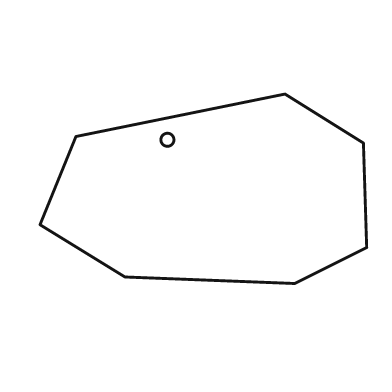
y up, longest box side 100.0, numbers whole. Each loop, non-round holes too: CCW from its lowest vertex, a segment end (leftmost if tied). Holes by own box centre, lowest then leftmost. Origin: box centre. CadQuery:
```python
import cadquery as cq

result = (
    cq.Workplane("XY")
    .moveTo(28.0, -29.0)
    .lineTo(50.0, -18.0)
    .lineTo(49.0, 14.0)
    .lineTo(25.0, 29.0)
    .lineTo(-39.0, 16.0)
    .lineTo(-50.0, -11.0)
    .lineTo(-24.0, -27.0)
    .close()
    .moveTo(-11.0, 15.0)
    .circle(2.0)
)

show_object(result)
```